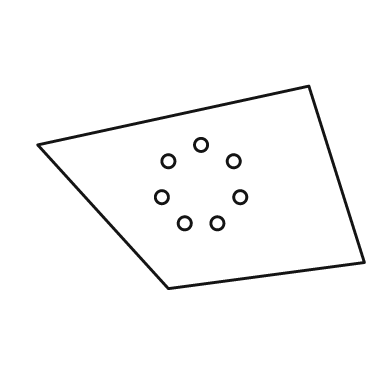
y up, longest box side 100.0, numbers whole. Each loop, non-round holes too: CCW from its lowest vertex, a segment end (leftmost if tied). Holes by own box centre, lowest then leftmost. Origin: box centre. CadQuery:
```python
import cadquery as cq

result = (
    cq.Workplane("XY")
    .moveTo(-10.0, -31.0)
    .lineTo(50.0, -23.0)
    .lineTo(33.0, 31.0)
    .lineTo(-50.0, 13.0)
    .close()
    .moveTo(-5.0, -11.0)
    .circle(2.0)
    .moveTo(5.0, -11.0)
    .circle(2.0)
    .moveTo(-12.0, -3.0)
    .circle(2.0)
    .moveTo(12.0, -3.0)
    .circle(2.0)
    .moveTo(-10.0, 8.0)
    .circle(2.0)
    .moveTo(10.0, 8.0)
    .circle(2.0)
    .moveTo(0.0, 13.0)
    .circle(2.0)
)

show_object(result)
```